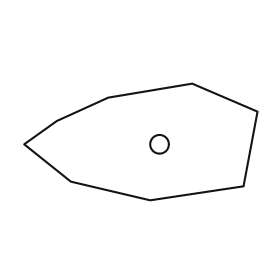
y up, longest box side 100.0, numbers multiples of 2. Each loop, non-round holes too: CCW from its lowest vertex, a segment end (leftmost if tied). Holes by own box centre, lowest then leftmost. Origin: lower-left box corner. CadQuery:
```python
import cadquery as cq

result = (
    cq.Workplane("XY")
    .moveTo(54.0, 0.0)
    .lineTo(94.0, 6.0)
    .lineTo(100.0, 38.0)
    .lineTo(72.0, 50.0)
    .lineTo(36.0, 44.0)
    .lineTo(14.0, 34.0)
    .lineTo(0.0, 24.0)
    .lineTo(20.0, 8.0)
    .close()
    .moveTo(58.0, 24.0)
    .circle(4.0)
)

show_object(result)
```